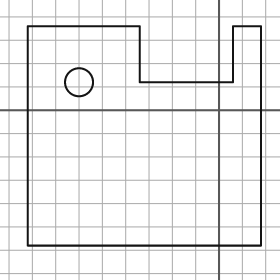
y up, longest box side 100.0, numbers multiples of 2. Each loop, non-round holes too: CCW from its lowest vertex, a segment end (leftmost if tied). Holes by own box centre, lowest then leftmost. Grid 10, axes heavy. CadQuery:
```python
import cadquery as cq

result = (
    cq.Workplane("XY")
    .moveTo(-82.0, -58.0)
    .lineTo(18.0, -58.0)
    .lineTo(18.0, 36.0)
    .lineTo(6.0, 36.0)
    .lineTo(6.0, 12.0)
    .lineTo(-34.0, 12.0)
    .lineTo(-34.0, 36.0)
    .lineTo(-82.0, 36.0)
    .close()
    .moveTo(-60.0, 12.0)
    .circle(6.0)
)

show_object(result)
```